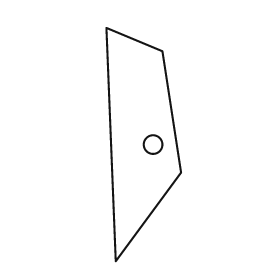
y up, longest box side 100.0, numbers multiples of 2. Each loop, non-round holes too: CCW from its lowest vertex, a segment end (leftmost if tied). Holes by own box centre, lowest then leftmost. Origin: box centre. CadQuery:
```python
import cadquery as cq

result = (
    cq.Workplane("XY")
    .moveTo(-12.0, -50.0)
    .lineTo(16.0, -12.0)
    .lineTo(8.0, 40.0)
    .lineTo(-16.0, 50.0)
    .close()
    .moveTo(4.0, 0.0)
    .circle(4.0)
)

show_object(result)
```